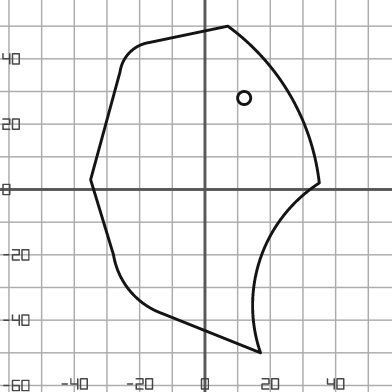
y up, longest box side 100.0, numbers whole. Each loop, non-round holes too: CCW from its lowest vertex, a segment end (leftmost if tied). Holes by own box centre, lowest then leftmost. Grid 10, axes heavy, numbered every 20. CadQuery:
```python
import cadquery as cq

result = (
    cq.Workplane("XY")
    .moveTo(17.0, -50.0)
    .threePointArc((17.0, -21.0), (35.0, 2.0))
    .threePointArc((26.0, 29.0), (7.0, 50.0))
    .lineTo(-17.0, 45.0)
    .threePointArc((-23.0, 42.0), (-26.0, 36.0))
    .lineTo(-35.0, 3.0)
    .lineTo(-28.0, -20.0)
    .threePointArc((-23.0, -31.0), (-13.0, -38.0))
    .close()
    .moveTo(12.0, 28.0)
    .circle(2.0)
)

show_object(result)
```